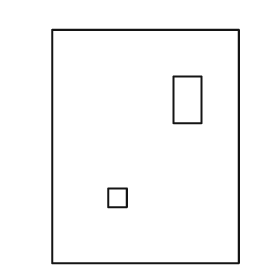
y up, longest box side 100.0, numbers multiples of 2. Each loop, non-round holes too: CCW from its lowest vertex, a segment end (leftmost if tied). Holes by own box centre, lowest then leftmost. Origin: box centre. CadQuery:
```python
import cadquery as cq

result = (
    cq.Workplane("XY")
    .moveTo(-40.0, -50.0)
    .lineTo(40.0, -50.0)
    .lineTo(40.0, 50.0)
    .lineTo(-40.0, 50.0)
    .close()
    .moveTo(-16.0, -26.0)
    .lineTo(-8.0, -26.0)
    .lineTo(-8.0, -18.0)
    .lineTo(-16.0, -18.0)
    .close()
    .moveTo(12.0, 10.0)
    .lineTo(24.0, 10.0)
    .lineTo(24.0, 30.0)
    .lineTo(12.0, 30.0)
    .close()
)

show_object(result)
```